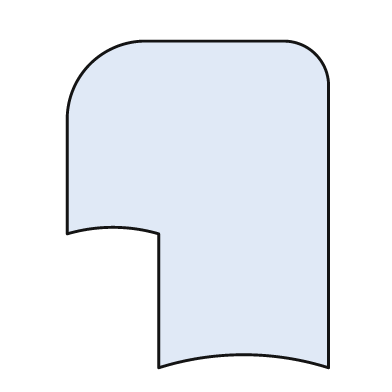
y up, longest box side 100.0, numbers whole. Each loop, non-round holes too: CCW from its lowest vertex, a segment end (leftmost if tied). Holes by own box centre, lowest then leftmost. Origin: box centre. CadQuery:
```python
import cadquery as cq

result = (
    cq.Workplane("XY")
    .moveTo(-12.0, -50.0)
    .threePointArc((14.0, -46.0), (40.0, -50.0))
    .lineTo(40.0, 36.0)
    .threePointArc((36.0, 46.0), (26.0, 50.0))
    .lineTo(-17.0, 50.0)
    .threePointArc((-33.0, 43.0), (-40.0, 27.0))
    .lineTo(-40.0, -9.0)
    .threePointArc((-26.0, -7.0), (-12.0, -9.0))
    .close()
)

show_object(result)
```